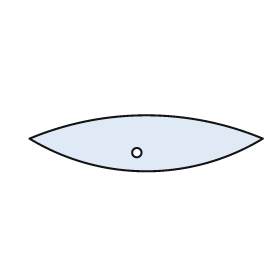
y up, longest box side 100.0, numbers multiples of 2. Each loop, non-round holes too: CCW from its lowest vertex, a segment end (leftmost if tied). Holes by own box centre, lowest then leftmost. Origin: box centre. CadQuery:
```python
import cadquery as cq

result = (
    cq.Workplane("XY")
    .moveTo(-50.0, 2.0)
    .threePointArc((0.0, -12.0), (50.0, 2.0))
    .threePointArc((0.0, 12.0), (-50.0, 2.0))
    .close()
    .moveTo(-4.0, -4.0)
    .circle(2.0)
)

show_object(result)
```